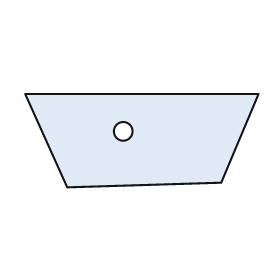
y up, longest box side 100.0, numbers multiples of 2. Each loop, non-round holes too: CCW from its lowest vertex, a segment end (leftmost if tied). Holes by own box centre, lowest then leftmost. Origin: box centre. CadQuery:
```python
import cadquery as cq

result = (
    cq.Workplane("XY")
    .moveTo(-32.0, -20.0)
    .lineTo(34.0, -18.0)
    .lineTo(50.0, 20.0)
    .lineTo(-50.0, 20.0)
    .close()
    .moveTo(-8.0, 4.0)
    .circle(4.0)
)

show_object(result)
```